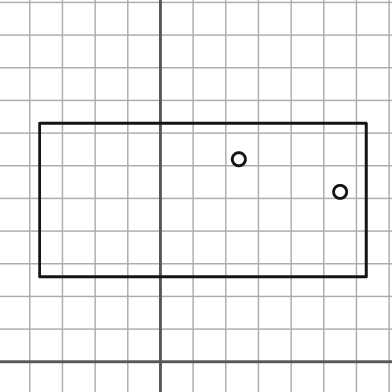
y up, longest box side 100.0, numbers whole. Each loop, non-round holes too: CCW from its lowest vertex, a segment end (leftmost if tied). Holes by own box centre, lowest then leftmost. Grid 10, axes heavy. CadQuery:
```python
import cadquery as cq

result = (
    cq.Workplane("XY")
    .moveTo(-37.0, 26.0)
    .lineTo(63.0, 26.0)
    .lineTo(63.0, 73.0)
    .lineTo(-37.0, 73.0)
    .close()
    .moveTo(55.0, 52.0)
    .circle(2.0)
    .moveTo(24.0, 62.0)
    .circle(2.0)
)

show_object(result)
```